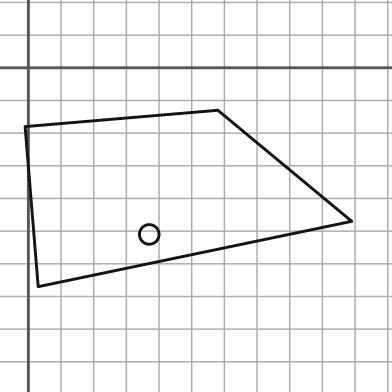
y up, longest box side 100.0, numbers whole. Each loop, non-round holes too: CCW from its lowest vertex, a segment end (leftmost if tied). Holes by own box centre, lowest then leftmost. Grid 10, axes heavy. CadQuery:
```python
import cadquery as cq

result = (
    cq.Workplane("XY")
    .moveTo(3.0, -67.0)
    .lineTo(99.0, -47.0)
    .lineTo(58.0, -13.0)
    .lineTo(-1.0, -18.0)
    .close()
    .moveTo(37.0, -51.0)
    .circle(3.0)
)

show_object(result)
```